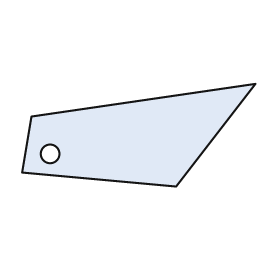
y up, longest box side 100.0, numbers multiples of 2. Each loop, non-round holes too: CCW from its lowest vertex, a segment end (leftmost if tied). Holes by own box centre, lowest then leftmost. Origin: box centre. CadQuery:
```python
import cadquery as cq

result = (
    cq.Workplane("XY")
    .moveTo(16.0, -22.0)
    .lineTo(50.0, 22.0)
    .lineTo(-46.0, 8.0)
    .lineTo(-50.0, -16.0)
    .close()
    .moveTo(-38.0, -8.0)
    .circle(4.0)
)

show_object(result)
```